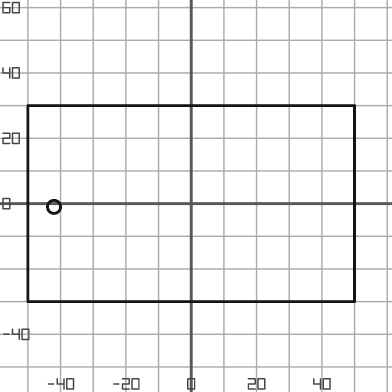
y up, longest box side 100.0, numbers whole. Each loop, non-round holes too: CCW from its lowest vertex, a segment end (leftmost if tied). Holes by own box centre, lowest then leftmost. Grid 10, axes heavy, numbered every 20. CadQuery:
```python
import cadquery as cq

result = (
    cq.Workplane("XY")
    .moveTo(-50.0, -30.0)
    .lineTo(50.0, -30.0)
    .lineTo(50.0, 30.0)
    .lineTo(-50.0, 30.0)
    .close()
    .moveTo(-42.0, -1.0)
    .circle(2.0)
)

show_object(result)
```